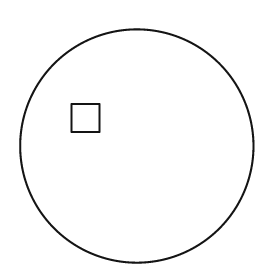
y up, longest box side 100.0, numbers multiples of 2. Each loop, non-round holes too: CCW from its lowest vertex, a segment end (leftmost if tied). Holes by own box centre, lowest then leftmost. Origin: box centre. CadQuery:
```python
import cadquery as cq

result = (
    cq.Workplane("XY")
    .moveTo(0.0, 0.0)
    .circle(50.0)
    .moveTo(-28.0, 6.0)
    .lineTo(-16.0, 6.0)
    .lineTo(-16.0, 18.0)
    .lineTo(-28.0, 18.0)
    .close()
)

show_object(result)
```